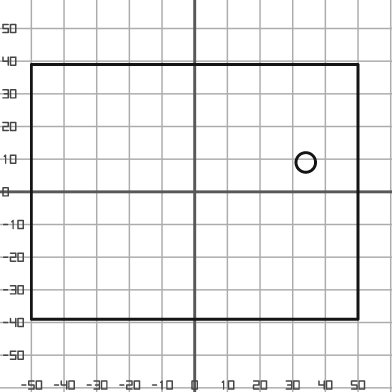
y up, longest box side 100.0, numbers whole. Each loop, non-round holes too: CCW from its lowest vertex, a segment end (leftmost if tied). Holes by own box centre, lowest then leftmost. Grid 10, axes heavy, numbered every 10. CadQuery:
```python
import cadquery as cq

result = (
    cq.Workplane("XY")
    .moveTo(-50.0, -39.0)
    .lineTo(50.0, -39.0)
    .lineTo(50.0, 39.0)
    .lineTo(-50.0, 39.0)
    .close()
    .moveTo(34.0, 9.0)
    .circle(3.0)
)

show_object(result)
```